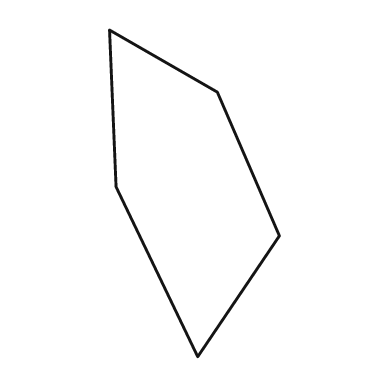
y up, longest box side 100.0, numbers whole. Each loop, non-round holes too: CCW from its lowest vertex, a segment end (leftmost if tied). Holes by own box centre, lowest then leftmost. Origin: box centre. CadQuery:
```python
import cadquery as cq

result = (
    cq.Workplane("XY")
    .moveTo(1.0, -50.0)
    .lineTo(26.0, -13.0)
    .lineTo(7.0, 31.0)
    .lineTo(-26.0, 50.0)
    .lineTo(-24.0, 2.0)
    .close()
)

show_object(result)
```